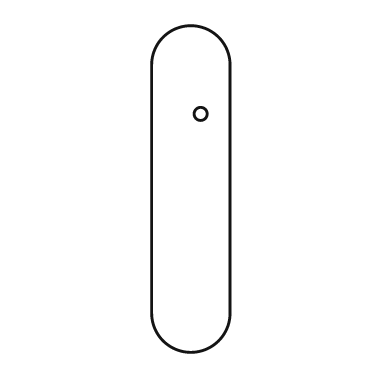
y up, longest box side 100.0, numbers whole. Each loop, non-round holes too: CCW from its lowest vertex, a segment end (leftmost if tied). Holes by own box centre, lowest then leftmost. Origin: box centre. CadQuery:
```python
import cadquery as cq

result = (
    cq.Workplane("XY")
    .moveTo(-12.0, -38.0)
    .threePointArc((0.0, -50.0), (12.0, -38.0))
    .lineTo(12.0, 38.0)
    .threePointArc((0.0, 50.0), (-12.0, 38.0))
    .close()
    .moveTo(3.0, 23.0)
    .circle(2.0)
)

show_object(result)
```